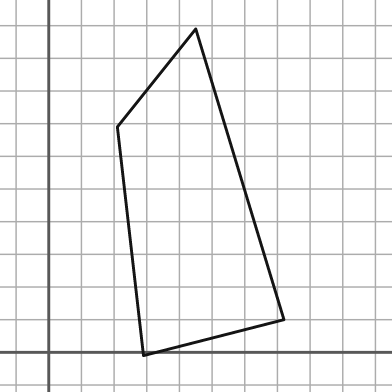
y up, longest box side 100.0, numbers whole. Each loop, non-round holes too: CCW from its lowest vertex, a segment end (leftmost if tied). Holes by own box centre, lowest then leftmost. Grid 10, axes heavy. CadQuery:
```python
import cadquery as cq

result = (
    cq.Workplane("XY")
    .moveTo(29.0, -1.0)
    .lineTo(72.0, 10.0)
    .lineTo(45.0, 99.0)
    .lineTo(21.0, 69.0)
    .close()
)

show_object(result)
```